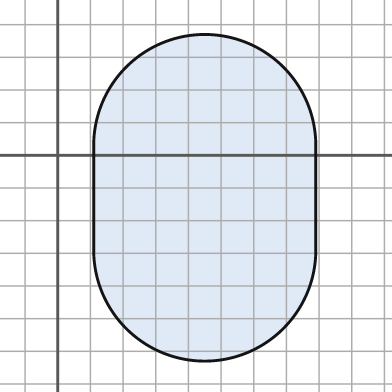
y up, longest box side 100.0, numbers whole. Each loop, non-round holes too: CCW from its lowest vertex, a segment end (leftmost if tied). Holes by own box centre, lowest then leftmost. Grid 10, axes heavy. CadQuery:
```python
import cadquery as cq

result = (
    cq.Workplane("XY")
    .moveTo(11.0, -29.0)
    .threePointArc((45.0, -63.0), (79.0, -29.0))
    .lineTo(79.0, 3.0)
    .threePointArc((45.0, 37.0), (11.0, 3.0))
    .close()
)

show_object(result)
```